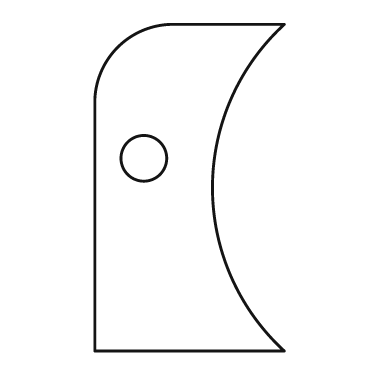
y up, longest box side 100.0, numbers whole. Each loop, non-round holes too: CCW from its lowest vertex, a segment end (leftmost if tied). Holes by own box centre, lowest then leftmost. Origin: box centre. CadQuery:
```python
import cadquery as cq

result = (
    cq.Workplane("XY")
    .moveTo(-29.0, -50.0)
    .lineTo(29.0, -50.0)
    .threePointArc((7.0, 0.0), (29.0, 50.0))
    .lineTo(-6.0, 50.0)
    .threePointArc((-22.0, 43.0), (-29.0, 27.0))
    .close()
    .moveTo(-14.0, 9.0)
    .circle(7.0)
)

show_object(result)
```